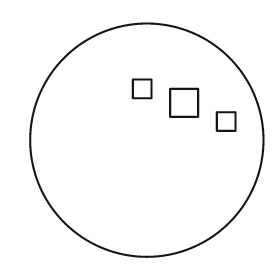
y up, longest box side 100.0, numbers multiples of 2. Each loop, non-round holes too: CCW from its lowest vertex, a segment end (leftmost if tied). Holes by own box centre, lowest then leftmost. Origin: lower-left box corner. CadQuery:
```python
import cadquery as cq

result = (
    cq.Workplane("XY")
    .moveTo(50.0, 50.0)
    .circle(50.0)
    .moveTo(80.0, 54.0)
    .lineTo(88.0, 54.0)
    .lineTo(88.0, 62.0)
    .lineTo(80.0, 62.0)
    .close()
    .moveTo(60.0, 60.0)
    .lineTo(72.0, 60.0)
    .lineTo(72.0, 72.0)
    .lineTo(60.0, 72.0)
    .close()
    .moveTo(44.0, 68.0)
    .lineTo(52.0, 68.0)
    .lineTo(52.0, 76.0)
    .lineTo(44.0, 76.0)
    .close()
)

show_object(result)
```